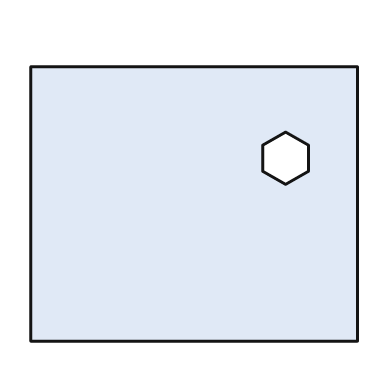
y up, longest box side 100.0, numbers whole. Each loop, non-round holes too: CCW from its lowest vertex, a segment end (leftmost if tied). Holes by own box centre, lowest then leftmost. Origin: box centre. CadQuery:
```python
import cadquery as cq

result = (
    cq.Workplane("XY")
    .moveTo(-50.0, -42.0)
    .lineTo(50.0, -42.0)
    .lineTo(50.0, 42.0)
    .lineTo(-50.0, 42.0)
    .close()
    .moveTo(28.0, 6.0)
    .lineTo(35.0, 10.0)
    .lineTo(35.0, 18.0)
    .lineTo(28.0, 22.0)
    .lineTo(21.0, 18.0)
    .lineTo(21.0, 10.0)
    .close()
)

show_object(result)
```